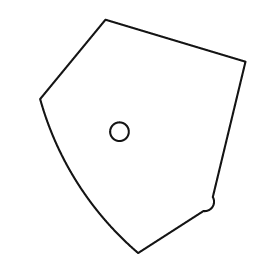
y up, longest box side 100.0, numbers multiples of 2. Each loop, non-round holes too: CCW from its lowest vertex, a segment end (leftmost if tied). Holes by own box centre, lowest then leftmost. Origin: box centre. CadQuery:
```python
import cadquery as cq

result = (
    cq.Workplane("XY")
    .moveTo(-2.0, -50.0)
    .lineTo(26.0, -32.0)
    .threePointArc((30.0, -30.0), (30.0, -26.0))
    .lineTo(44.0, 32.0)
    .lineTo(-16.0, 50.0)
    .lineTo(-44.0, 16.0)
    .threePointArc((-28.0, -20.0), (-2.0, -50.0))
    .close()
    .moveTo(-10.0, 2.0)
    .circle(4.0)
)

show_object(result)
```